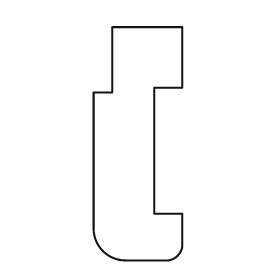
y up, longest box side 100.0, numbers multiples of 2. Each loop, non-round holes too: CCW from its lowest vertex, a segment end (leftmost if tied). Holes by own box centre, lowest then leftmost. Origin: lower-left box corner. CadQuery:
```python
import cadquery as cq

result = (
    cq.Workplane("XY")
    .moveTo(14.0, 0.0)
    .lineTo(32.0, 0.0)
    .threePointArc((36.0, 2.0), (38.0, 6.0))
    .lineTo(38.0, 20.0)
    .lineTo(26.0, 20.0)
    .lineTo(26.0, 74.0)
    .lineTo(38.0, 74.0)
    .lineTo(38.0, 100.0)
    .lineTo(8.0, 100.0)
    .lineTo(8.0, 72.0)
    .lineTo(0.0, 72.0)
    .lineTo(0.0, 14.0)
    .threePointArc((4.0, 4.0), (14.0, 0.0))
    .close()
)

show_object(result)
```